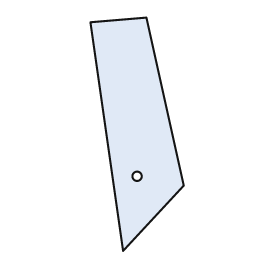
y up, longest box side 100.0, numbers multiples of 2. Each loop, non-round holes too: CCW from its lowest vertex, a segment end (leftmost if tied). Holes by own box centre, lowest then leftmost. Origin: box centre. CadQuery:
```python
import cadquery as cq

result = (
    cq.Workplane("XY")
    .moveTo(-6.0, -50.0)
    .lineTo(20.0, -22.0)
    .lineTo(4.0, 50.0)
    .lineTo(-20.0, 48.0)
    .close()
    .moveTo(0.0, -18.0)
    .circle(2.0)
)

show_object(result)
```